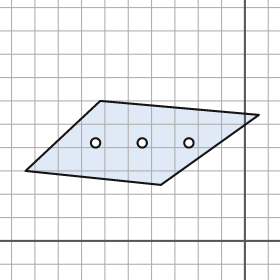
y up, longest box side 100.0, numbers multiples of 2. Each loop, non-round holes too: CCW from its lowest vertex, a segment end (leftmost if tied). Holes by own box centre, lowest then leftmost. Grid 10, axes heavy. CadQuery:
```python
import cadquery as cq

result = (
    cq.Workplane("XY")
    .moveTo(-36.0, 24.0)
    .lineTo(6.0, 54.0)
    .lineTo(-62.0, 60.0)
    .lineTo(-94.0, 30.0)
    .close()
    .moveTo(-64.0, 42.0)
    .circle(2.0)
    .moveTo(-44.0, 42.0)
    .circle(2.0)
    .moveTo(-24.0, 42.0)
    .circle(2.0)
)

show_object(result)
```